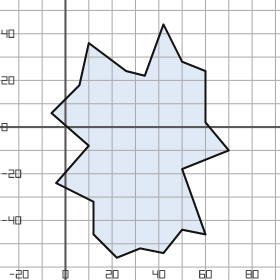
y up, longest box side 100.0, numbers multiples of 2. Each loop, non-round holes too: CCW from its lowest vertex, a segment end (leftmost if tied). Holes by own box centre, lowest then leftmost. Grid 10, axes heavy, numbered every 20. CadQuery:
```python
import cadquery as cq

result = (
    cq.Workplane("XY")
    .moveTo(22.0, -56.0)
    .lineTo(32.0, -52.0)
    .lineTo(42.0, -54.0)
    .lineTo(50.0, -44.0)
    .lineTo(60.0, -46.0)
    .lineTo(50.0, -18.0)
    .lineTo(70.0, -10.0)
    .lineTo(60.0, 2.0)
    .lineTo(60.0, 24.0)
    .lineTo(50.0, 28.0)
    .lineTo(42.0, 44.0)
    .lineTo(34.0, 22.0)
    .lineTo(26.0, 24.0)
    .lineTo(10.0, 36.0)
    .lineTo(6.0, 18.0)
    .lineTo(-6.0, 6.0)
    .lineTo(10.0, -8.0)
    .lineTo(-4.0, -24.0)
    .lineTo(12.0, -32.0)
    .lineTo(12.0, -46.0)
    .close()
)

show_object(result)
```